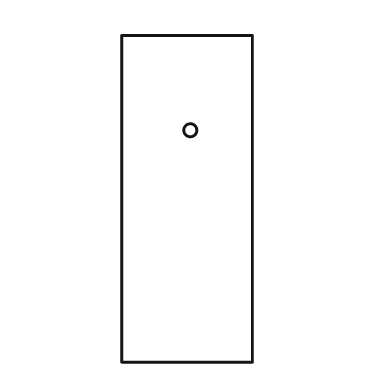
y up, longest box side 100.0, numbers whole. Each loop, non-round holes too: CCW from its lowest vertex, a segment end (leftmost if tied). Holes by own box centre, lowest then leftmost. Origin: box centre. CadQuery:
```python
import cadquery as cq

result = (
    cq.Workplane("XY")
    .moveTo(-20.0, -50.0)
    .lineTo(20.0, -50.0)
    .lineTo(20.0, 50.0)
    .lineTo(-20.0, 50.0)
    .close()
    .moveTo(1.0, 21.0)
    .circle(2.0)
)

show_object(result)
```